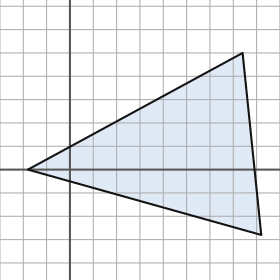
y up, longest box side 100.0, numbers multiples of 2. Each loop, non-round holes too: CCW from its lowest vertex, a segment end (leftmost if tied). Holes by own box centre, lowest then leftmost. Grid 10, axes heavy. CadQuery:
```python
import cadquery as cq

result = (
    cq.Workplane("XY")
    .moveTo(82.0, -28.0)
    .lineTo(74.0, 50.0)
    .lineTo(-18.0, 0.0)
    .close()
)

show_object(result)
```